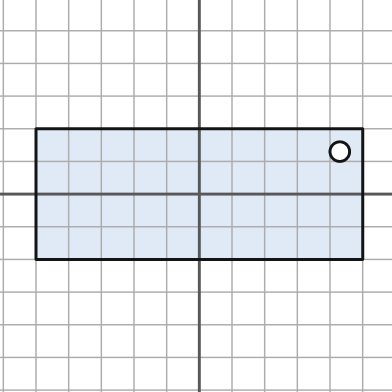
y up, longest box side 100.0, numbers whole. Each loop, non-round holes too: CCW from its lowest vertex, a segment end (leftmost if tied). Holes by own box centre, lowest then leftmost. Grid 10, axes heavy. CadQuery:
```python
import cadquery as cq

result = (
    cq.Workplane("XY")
    .moveTo(-50.0, -20.0)
    .lineTo(50.0, -20.0)
    .lineTo(50.0, 20.0)
    .lineTo(-50.0, 20.0)
    .close()
    .moveTo(43.0, 13.0)
    .circle(3.0)
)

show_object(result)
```